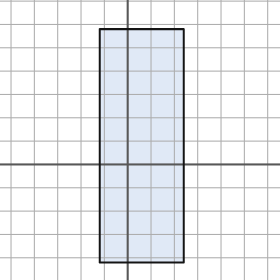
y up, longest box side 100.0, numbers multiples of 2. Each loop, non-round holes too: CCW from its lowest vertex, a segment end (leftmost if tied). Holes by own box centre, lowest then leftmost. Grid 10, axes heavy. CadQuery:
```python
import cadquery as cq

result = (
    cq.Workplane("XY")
    .moveTo(-12.0, -42.0)
    .lineTo(24.0, -42.0)
    .lineTo(24.0, 58.0)
    .lineTo(-12.0, 58.0)
    .close()
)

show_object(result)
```